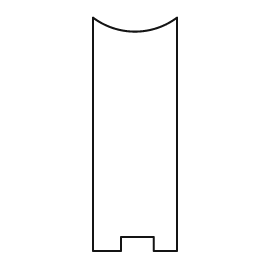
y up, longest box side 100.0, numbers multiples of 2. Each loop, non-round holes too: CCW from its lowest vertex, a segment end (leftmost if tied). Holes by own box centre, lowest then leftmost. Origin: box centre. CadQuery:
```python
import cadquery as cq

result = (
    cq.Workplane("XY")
    .moveTo(-18.0, -50.0)
    .lineTo(-6.0, -50.0)
    .lineTo(-6.0, -44.0)
    .lineTo(8.0, -44.0)
    .lineTo(8.0, -50.0)
    .lineTo(18.0, -50.0)
    .lineTo(18.0, 50.0)
    .threePointArc((0.0, 44.0), (-18.0, 50.0))
    .close()
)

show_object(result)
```